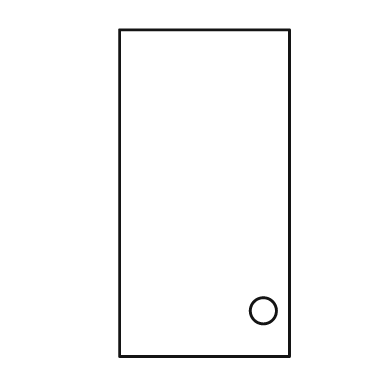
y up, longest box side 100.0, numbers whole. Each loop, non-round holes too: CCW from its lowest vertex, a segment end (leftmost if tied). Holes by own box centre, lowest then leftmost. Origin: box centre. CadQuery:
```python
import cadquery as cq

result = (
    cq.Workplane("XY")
    .moveTo(-26.0, -50.0)
    .lineTo(26.0, -50.0)
    .lineTo(26.0, 50.0)
    .lineTo(-26.0, 50.0)
    .close()
    .moveTo(18.0, -36.0)
    .circle(4.0)
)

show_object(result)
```